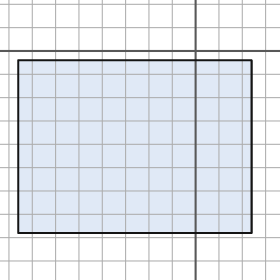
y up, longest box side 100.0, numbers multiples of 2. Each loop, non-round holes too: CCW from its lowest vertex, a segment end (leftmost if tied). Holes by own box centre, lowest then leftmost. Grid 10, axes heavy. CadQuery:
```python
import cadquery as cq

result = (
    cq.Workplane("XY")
    .moveTo(-76.0, -78.0)
    .lineTo(24.0, -78.0)
    .lineTo(24.0, -4.0)
    .lineTo(-76.0, -4.0)
    .close()
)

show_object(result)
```